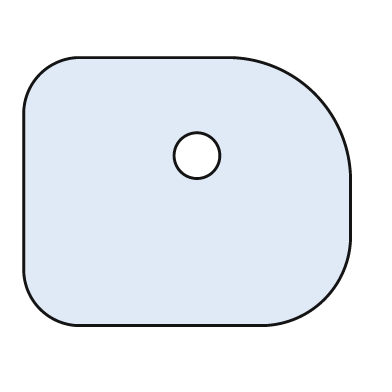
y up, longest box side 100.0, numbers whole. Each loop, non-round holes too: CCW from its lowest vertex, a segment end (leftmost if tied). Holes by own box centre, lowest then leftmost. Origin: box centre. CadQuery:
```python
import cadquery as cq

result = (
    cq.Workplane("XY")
    .moveTo(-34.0, -41.0)
    .lineTo(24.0, -41.0)
    .threePointArc((42.0, -33.0), (50.0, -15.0))
    .lineTo(50.0, 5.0)
    .threePointArc((39.0, 30.0), (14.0, 41.0))
    .lineTo(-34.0, 41.0)
    .threePointArc((-45.0, 36.0), (-50.0, 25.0))
    .lineTo(-50.0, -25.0)
    .threePointArc((-45.0, -36.0), (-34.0, -41.0))
    .close()
    .moveTo(3.0, 11.0)
    .circle(7.0)
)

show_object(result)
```